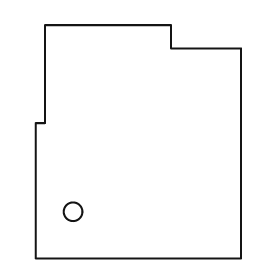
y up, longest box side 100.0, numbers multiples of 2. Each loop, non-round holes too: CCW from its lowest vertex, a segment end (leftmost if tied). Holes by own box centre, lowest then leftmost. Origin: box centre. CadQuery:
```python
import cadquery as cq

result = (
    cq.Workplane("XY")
    .moveTo(-44.0, -50.0)
    .lineTo(44.0, -50.0)
    .lineTo(44.0, 40.0)
    .lineTo(14.0, 40.0)
    .lineTo(14.0, 50.0)
    .lineTo(-40.0, 50.0)
    .lineTo(-40.0, 8.0)
    .lineTo(-44.0, 8.0)
    .close()
    .moveTo(-28.0, -30.0)
    .circle(4.0)
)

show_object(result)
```